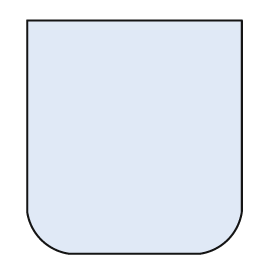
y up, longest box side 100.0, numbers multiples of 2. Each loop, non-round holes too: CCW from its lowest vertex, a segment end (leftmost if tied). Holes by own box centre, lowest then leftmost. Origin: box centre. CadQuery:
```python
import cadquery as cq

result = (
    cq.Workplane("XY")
    .moveTo(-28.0, -50.0)
    .lineTo(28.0, -50.0)
    .threePointArc((40.0, -44.0), (46.0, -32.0))
    .lineTo(46.0, 50.0)
    .lineTo(-46.0, 50.0)
    .lineTo(-46.0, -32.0)
    .threePointArc((-40.0, -44.0), (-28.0, -50.0))
    .close()
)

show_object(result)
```